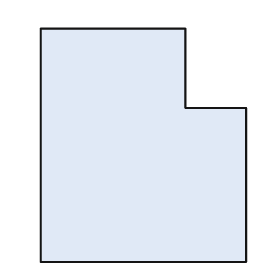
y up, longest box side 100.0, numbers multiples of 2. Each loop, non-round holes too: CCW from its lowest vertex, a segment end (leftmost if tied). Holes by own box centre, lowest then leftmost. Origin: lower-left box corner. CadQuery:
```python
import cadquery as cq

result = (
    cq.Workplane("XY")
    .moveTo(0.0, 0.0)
    .lineTo(88.0, 0.0)
    .lineTo(88.0, 66.0)
    .lineTo(62.0, 66.0)
    .lineTo(62.0, 100.0)
    .lineTo(0.0, 100.0)
    .close()
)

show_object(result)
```